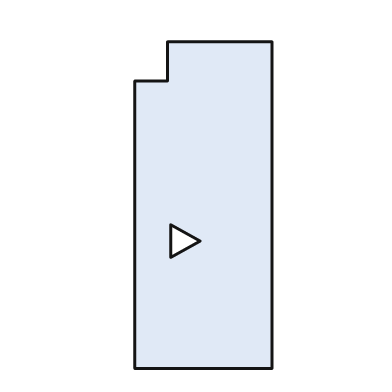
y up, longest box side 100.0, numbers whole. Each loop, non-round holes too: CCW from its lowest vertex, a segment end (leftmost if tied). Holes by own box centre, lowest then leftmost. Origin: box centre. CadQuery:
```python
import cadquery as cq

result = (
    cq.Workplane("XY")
    .moveTo(-21.0, -50.0)
    .lineTo(21.0, -50.0)
    .lineTo(21.0, 50.0)
    .lineTo(-11.0, 50.0)
    .lineTo(-11.0, 38.0)
    .lineTo(-21.0, 38.0)
    .close()
    .moveTo(-10.0, -16.0)
    .lineTo(-1.0, -11.0)
    .lineTo(-10.0, -6.0)
    .close()
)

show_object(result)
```